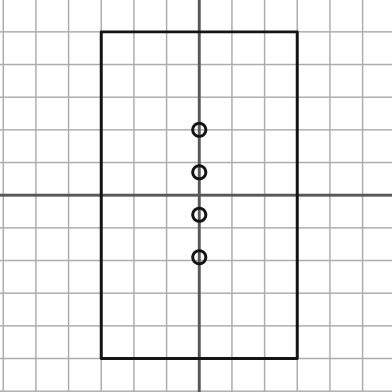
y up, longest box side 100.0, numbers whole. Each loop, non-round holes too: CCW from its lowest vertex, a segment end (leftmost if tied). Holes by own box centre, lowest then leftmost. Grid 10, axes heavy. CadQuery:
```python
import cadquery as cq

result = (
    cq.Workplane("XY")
    .moveTo(-30.0, -50.0)
    .lineTo(30.0, -50.0)
    .lineTo(30.0, 50.0)
    .lineTo(-30.0, 50.0)
    .close()
    .moveTo(0.0, -19.0)
    .circle(2.0)
    .moveTo(0.0, -6.0)
    .circle(2.0)
    .moveTo(0.0, 7.0)
    .circle(2.0)
    .moveTo(0.0, 20.0)
    .circle(2.0)
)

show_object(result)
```